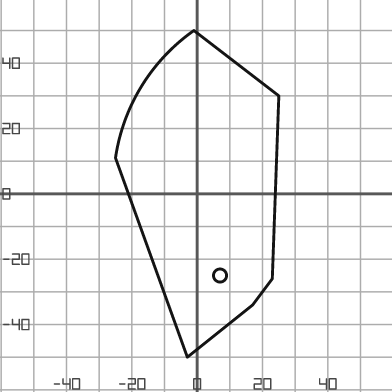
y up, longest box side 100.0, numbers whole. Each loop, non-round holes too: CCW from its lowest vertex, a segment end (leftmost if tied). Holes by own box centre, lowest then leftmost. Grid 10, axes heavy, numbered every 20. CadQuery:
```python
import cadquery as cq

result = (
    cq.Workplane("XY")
    .moveTo(-3.0, -50.0)
    .lineTo(17.0, -34.0)
    .lineTo(23.0, -26.0)
    .lineTo(25.0, 30.0)
    .lineTo(-1.0, 50.0)
    .threePointArc((-17.0, 33.0), (-25.0, 11.0))
    .close()
    .moveTo(7.0, -25.0)
    .circle(2.0)
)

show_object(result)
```